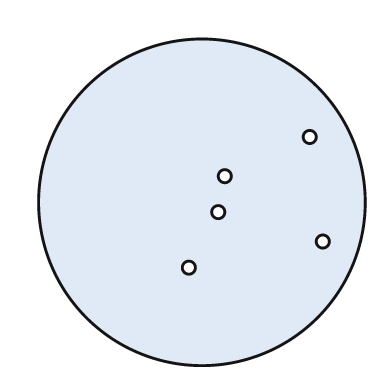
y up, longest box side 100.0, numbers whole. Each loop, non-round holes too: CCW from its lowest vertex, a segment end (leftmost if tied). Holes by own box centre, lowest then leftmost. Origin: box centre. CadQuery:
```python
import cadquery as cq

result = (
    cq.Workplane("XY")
    .moveTo(0.0, 0.0)
    .circle(50.0)
    .moveTo(-4.0, -20.0)
    .circle(2.0)
    .moveTo(37.0, -12.0)
    .circle(2.0)
    .moveTo(5.0, -3.0)
    .circle(2.0)
    .moveTo(7.0, 8.0)
    .circle(2.0)
    .moveTo(33.0, 20.0)
    .circle(2.0)
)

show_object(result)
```